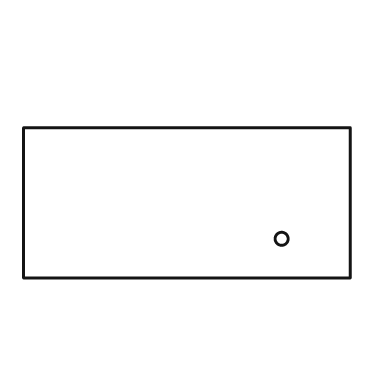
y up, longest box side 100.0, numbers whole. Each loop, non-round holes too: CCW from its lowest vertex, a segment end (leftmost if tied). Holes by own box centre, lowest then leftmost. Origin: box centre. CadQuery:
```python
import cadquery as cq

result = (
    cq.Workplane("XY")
    .moveTo(-50.0, -23.0)
    .lineTo(50.0, -23.0)
    .lineTo(50.0, 23.0)
    .lineTo(-50.0, 23.0)
    .close()
    .moveTo(29.0, -11.0)
    .circle(2.0)
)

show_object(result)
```